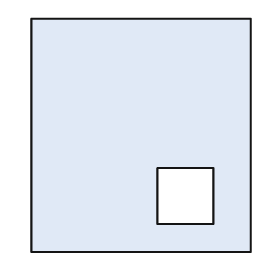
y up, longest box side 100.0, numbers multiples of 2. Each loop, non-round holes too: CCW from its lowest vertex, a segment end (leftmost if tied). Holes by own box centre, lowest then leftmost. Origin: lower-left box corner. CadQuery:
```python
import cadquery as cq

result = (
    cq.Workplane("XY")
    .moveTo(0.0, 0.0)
    .lineTo(94.0, 0.0)
    .lineTo(94.0, 100.0)
    .lineTo(0.0, 100.0)
    .close()
    .moveTo(54.0, 12.0)
    .lineTo(78.0, 12.0)
    .lineTo(78.0, 36.0)
    .lineTo(54.0, 36.0)
    .close()
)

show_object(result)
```